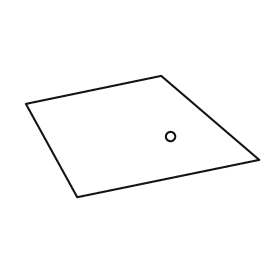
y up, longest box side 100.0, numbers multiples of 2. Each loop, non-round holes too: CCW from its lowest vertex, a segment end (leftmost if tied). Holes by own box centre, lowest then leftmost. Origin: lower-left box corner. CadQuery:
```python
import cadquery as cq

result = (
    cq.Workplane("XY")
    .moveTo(22.0, 0.0)
    .lineTo(100.0, 16.0)
    .lineTo(58.0, 52.0)
    .lineTo(0.0, 40.0)
    .close()
    .moveTo(62.0, 26.0)
    .circle(2.0)
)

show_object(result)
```